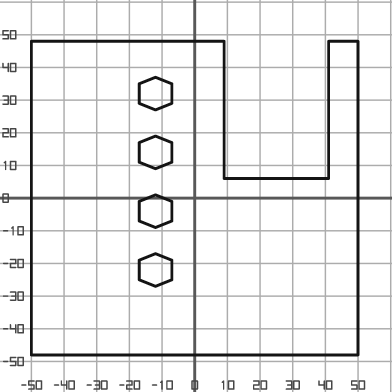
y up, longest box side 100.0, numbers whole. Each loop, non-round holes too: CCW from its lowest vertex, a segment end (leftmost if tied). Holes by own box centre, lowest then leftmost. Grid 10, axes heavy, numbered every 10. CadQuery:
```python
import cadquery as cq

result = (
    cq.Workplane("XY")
    .moveTo(-50.0, -48.0)
    .lineTo(50.0, -48.0)
    .lineTo(50.0, 48.0)
    .lineTo(41.0, 48.0)
    .lineTo(41.0, 6.0)
    .lineTo(9.0, 6.0)
    .lineTo(9.0, 48.0)
    .lineTo(-50.0, 48.0)
    .close()
    .moveTo(-12.0, -27.0)
    .lineTo(-7.0, -25.0)
    .lineTo(-7.0, -19.0)
    .lineTo(-12.0, -17.0)
    .lineTo(-17.0, -19.0)
    .lineTo(-17.0, -25.0)
    .close()
    .moveTo(-12.0, -9.0)
    .lineTo(-7.0, -7.0)
    .lineTo(-7.0, -1.0)
    .lineTo(-12.0, 1.0)
    .lineTo(-17.0, -1.0)
    .lineTo(-17.0, -7.0)
    .close()
    .moveTo(-12.0, 9.0)
    .lineTo(-7.0, 11.0)
    .lineTo(-7.0, 17.0)
    .lineTo(-12.0, 19.0)
    .lineTo(-17.0, 17.0)
    .lineTo(-17.0, 11.0)
    .close()
    .moveTo(-12.0, 27.0)
    .lineTo(-7.0, 29.0)
    .lineTo(-7.0, 35.0)
    .lineTo(-12.0, 37.0)
    .lineTo(-17.0, 35.0)
    .lineTo(-17.0, 29.0)
    .close()
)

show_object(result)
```